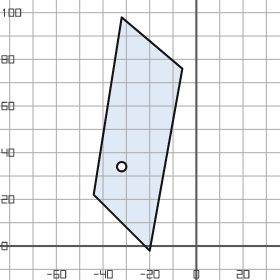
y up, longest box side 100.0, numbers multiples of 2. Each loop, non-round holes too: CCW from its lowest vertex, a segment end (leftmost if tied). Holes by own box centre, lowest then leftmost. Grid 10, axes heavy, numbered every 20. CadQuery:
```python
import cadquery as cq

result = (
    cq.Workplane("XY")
    .moveTo(-20.0, -2.0)
    .lineTo(-6.0, 76.0)
    .lineTo(-32.0, 98.0)
    .lineTo(-44.0, 22.0)
    .close()
    .moveTo(-32.0, 34.0)
    .circle(2.0)
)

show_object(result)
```